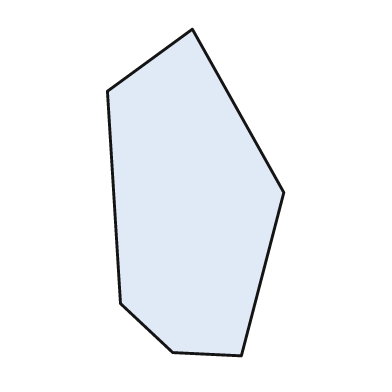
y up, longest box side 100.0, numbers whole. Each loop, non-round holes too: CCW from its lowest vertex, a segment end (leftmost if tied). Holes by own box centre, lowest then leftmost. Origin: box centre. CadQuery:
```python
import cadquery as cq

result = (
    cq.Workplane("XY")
    .moveTo(14.0, -50.0)
    .lineTo(27.0, 0.0)
    .lineTo(-1.0, 50.0)
    .lineTo(-27.0, 31.0)
    .lineTo(-23.0, -34.0)
    .lineTo(-7.0, -49.0)
    .close()
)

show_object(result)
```